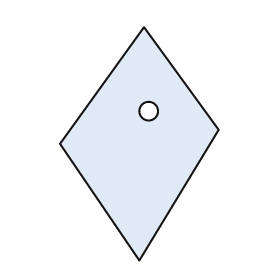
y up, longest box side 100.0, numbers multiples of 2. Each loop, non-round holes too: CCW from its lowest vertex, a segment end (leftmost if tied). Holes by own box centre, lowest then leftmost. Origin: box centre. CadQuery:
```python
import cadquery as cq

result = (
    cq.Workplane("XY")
    .moveTo(0.0, -50.0)
    .lineTo(34.0, 6.0)
    .lineTo(2.0, 50.0)
    .lineTo(-34.0, 0.0)
    .close()
    .moveTo(4.0, 14.0)
    .circle(4.0)
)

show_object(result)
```